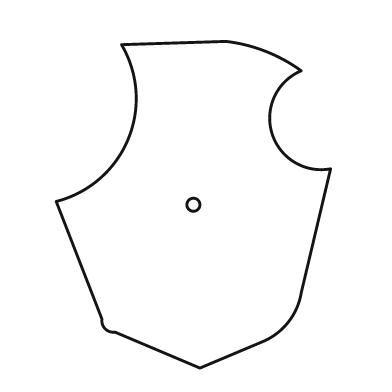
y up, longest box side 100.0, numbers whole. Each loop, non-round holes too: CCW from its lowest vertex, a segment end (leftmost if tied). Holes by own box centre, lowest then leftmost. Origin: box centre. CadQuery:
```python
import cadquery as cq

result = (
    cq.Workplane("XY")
    .moveTo(2.0, -50.0)
    .lineTo(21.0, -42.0)
    .threePointArc((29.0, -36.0), (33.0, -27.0))
    .lineTo(42.0, 11.0)
    .threePointArc((24.0, 22.0), (33.0, 41.0))
    .threePointArc((22.0, 47.0), (10.0, 50.0))
    .lineTo(-22.0, 49.0)
    .threePointArc((-20.0, 20.0), (-42.0, 1.0))
    .lineTo(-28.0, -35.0)
    .threePointArc((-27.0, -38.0), (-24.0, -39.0))
    .close()
    .moveTo(0.0, 0.0)
    .circle(2.0)
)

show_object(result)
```